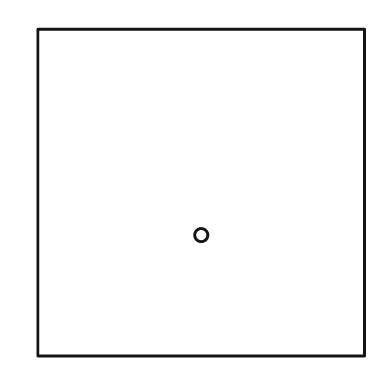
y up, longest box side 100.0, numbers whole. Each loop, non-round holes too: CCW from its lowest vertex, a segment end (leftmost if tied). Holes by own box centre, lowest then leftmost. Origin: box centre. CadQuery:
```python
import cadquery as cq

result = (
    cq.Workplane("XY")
    .moveTo(-50.0, -50.0)
    .lineTo(50.0, -50.0)
    .lineTo(50.0, 50.0)
    .lineTo(-50.0, 50.0)
    .close()
    .moveTo(0.0, -13.0)
    .circle(2.0)
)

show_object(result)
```